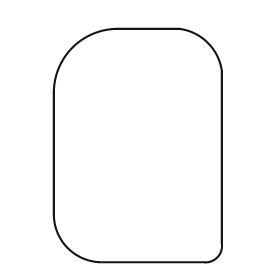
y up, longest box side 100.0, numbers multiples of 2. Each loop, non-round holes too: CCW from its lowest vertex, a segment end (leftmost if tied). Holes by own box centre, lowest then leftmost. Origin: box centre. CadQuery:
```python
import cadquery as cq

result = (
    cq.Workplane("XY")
    .moveTo(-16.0, -50.0)
    .lineTo(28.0, -50.0)
    .threePointArc((34.0, -48.0), (36.0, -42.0))
    .lineTo(36.0, 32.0)
    .threePointArc((30.0, 44.0), (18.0, 50.0))
    .lineTo(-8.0, 50.0)
    .threePointArc((-28.0, 42.0), (-36.0, 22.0))
    .lineTo(-36.0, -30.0)
    .threePointArc((-30.0, -44.0), (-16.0, -50.0))
    .close()
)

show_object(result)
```